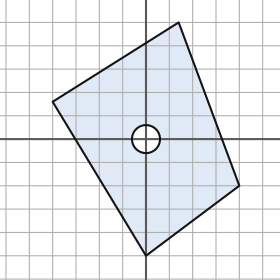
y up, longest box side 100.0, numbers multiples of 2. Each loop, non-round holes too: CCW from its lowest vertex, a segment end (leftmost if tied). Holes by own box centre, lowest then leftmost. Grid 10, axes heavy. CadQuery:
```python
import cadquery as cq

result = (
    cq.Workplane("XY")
    .moveTo(0.0, -50.0)
    .lineTo(40.0, -20.0)
    .lineTo(14.0, 50.0)
    .lineTo(-40.0, 16.0)
    .close()
    .moveTo(0.0, 0.0)
    .circle(6.0)
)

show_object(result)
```